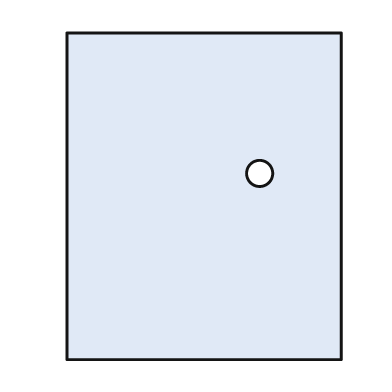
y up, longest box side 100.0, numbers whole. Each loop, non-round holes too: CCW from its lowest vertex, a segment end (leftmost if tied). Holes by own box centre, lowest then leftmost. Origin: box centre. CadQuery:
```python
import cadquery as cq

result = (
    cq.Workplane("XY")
    .moveTo(-42.0, -50.0)
    .lineTo(42.0, -50.0)
    .lineTo(42.0, 50.0)
    .lineTo(-42.0, 50.0)
    .close()
    .moveTo(17.0, 7.0)
    .circle(4.0)
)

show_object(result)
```